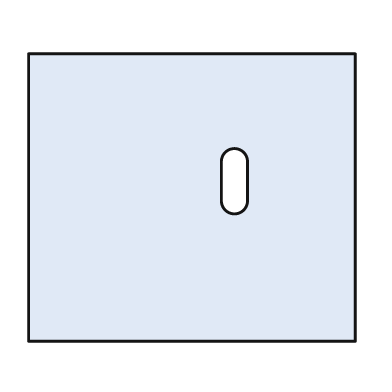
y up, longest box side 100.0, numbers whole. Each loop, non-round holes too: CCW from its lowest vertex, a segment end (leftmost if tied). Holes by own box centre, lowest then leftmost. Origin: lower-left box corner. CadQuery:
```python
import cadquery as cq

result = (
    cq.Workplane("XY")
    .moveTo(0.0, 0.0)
    .lineTo(100.0, 0.0)
    .lineTo(100.0, 88.0)
    .lineTo(0.0, 88.0)
    .close()
    .moveTo(59.0, 43.0)
    .threePointArc((63.0, 39.0), (67.0, 43.0))
    .lineTo(67.0, 55.0)
    .threePointArc((63.0, 59.0), (59.0, 55.0))
    .close()
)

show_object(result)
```